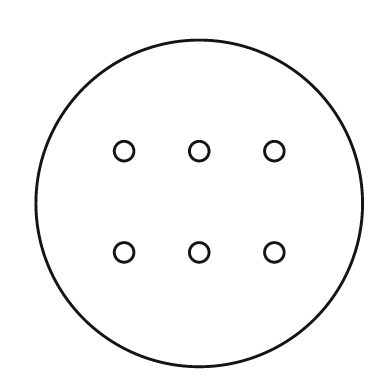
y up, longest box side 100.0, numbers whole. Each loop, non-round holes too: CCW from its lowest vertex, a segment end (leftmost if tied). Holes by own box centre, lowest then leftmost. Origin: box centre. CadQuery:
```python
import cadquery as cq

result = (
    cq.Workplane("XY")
    .moveTo(0.0, 0.0)
    .circle(50.0)
    .moveTo(-23.0, -15.0)
    .circle(3.0)
    .moveTo(0.0, -15.0)
    .circle(3.0)
    .moveTo(23.0, -15.0)
    .circle(3.0)
    .moveTo(-23.0, 16.0)
    .circle(3.0)
    .moveTo(0.0, 16.0)
    .circle(3.0)
    .moveTo(23.0, 16.0)
    .circle(3.0)
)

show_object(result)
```